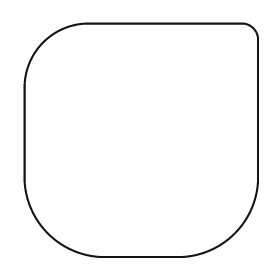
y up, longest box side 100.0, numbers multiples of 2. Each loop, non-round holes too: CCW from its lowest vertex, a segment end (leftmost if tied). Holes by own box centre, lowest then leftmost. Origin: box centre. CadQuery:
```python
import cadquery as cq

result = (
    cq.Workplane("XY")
    .moveTo(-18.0, -50.0)
    .lineTo(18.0, -50.0)
    .threePointArc((40.0, -40.0), (50.0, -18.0))
    .lineTo(50.0, 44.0)
    .threePointArc((48.0, 48.0), (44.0, 50.0))
    .lineTo(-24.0, 50.0)
    .threePointArc((-42.0, 42.0), (-50.0, 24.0))
    .lineTo(-50.0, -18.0)
    .threePointArc((-40.0, -40.0), (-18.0, -50.0))
    .close()
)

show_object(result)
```